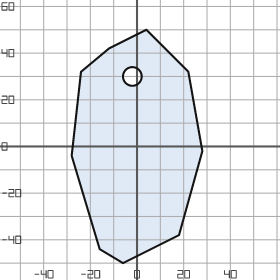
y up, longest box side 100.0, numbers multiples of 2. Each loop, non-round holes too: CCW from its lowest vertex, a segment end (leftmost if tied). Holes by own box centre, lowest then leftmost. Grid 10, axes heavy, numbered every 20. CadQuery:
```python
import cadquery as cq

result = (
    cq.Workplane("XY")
    .moveTo(-6.0, -50.0)
    .lineTo(18.0, -38.0)
    .lineTo(28.0, -2.0)
    .lineTo(22.0, 32.0)
    .lineTo(4.0, 50.0)
    .lineTo(-12.0, 42.0)
    .lineTo(-24.0, 32.0)
    .lineTo(-28.0, -4.0)
    .lineTo(-16.0, -44.0)
    .close()
    .moveTo(-2.0, 30.0)
    .circle(4.0)
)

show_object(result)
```